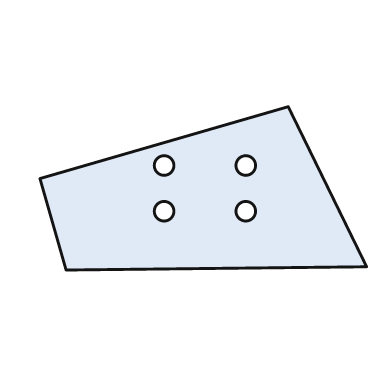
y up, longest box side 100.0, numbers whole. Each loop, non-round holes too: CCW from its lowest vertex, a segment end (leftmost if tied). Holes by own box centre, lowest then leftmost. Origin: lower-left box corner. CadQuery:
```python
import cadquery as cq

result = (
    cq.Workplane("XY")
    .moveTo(8.0, 0.0)
    .lineTo(100.0, 1.0)
    .lineTo(76.0, 50.0)
    .lineTo(0.0, 28.0)
    .close()
    .moveTo(38.0, 18.0)
    .circle(3.0)
    .moveTo(63.0, 18.0)
    .circle(3.0)
    .moveTo(38.0, 32.0)
    .circle(3.0)
    .moveTo(63.0, 32.0)
    .circle(3.0)
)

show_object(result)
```